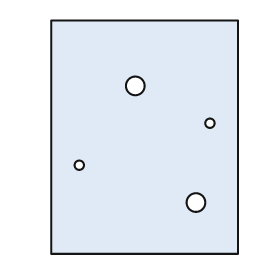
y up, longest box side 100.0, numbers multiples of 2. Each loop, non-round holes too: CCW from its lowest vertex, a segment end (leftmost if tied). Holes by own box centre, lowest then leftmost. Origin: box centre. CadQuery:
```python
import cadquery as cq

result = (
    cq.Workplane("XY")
    .moveTo(-40.0, -50.0)
    .lineTo(40.0, -50.0)
    .lineTo(40.0, 50.0)
    .lineTo(-40.0, 50.0)
    .close()
    .moveTo(22.0, -28.0)
    .circle(4.0)
    .moveTo(-28.0, -12.0)
    .circle(2.0)
    .moveTo(28.0, 6.0)
    .circle(2.0)
    .moveTo(-4.0, 22.0)
    .circle(4.0)
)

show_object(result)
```